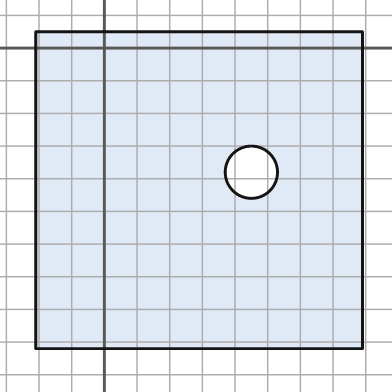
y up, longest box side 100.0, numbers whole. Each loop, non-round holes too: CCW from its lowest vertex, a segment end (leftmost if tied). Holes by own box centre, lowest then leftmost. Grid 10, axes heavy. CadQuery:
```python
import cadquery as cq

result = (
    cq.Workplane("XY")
    .moveTo(-21.0, -92.0)
    .lineTo(79.0, -92.0)
    .lineTo(79.0, 5.0)
    .lineTo(-21.0, 5.0)
    .close()
    .moveTo(45.0, -38.0)
    .circle(8.0)
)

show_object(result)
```